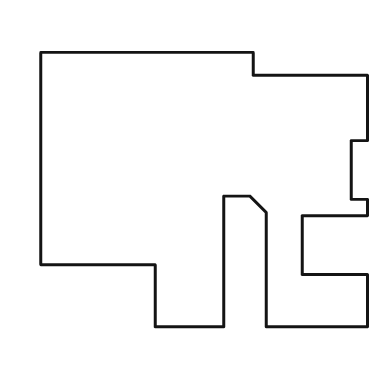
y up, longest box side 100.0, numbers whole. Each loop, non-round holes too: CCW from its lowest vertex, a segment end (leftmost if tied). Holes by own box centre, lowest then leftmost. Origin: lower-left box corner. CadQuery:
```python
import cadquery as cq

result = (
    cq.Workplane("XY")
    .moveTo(35.0, 0.0)
    .lineTo(56.0, 0.0)
    .lineTo(56.0, 40.0)
    .lineTo(64.0, 40.0)
    .lineTo(69.0, 35.0)
    .lineTo(69.0, 0.0)
    .lineTo(100.0, 0.0)
    .lineTo(100.0, 16.0)
    .lineTo(80.0, 16.0)
    .lineTo(80.0, 34.0)
    .lineTo(100.0, 34.0)
    .lineTo(100.0, 39.0)
    .lineTo(95.0, 39.0)
    .lineTo(95.0, 57.0)
    .lineTo(100.0, 57.0)
    .lineTo(100.0, 77.0)
    .lineTo(65.0, 77.0)
    .lineTo(65.0, 84.0)
    .lineTo(0.0, 84.0)
    .lineTo(0.0, 19.0)
    .lineTo(35.0, 19.0)
    .close()
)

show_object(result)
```